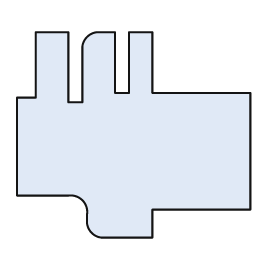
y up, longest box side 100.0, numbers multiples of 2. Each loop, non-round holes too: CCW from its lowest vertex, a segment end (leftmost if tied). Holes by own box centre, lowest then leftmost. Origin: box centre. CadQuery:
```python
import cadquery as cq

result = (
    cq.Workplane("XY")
    .moveTo(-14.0, -44.0)
    .lineTo(8.0, -44.0)
    .lineTo(8.0, -32.0)
    .lineTo(50.0, -32.0)
    .lineTo(50.0, 18.0)
    .lineTo(8.0, 18.0)
    .lineTo(8.0, 44.0)
    .lineTo(-2.0, 44.0)
    .lineTo(-2.0, 18.0)
    .lineTo(-8.0, 18.0)
    .lineTo(-8.0, 44.0)
    .lineTo(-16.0, 44.0)
    .threePointArc((-20.0, 42.0), (-22.0, 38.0))
    .lineTo(-22.0, 14.0)
    .lineTo(-28.0, 14.0)
    .lineTo(-28.0, 44.0)
    .lineTo(-42.0, 44.0)
    .lineTo(-42.0, 16.0)
    .lineTo(-50.0, 16.0)
    .lineTo(-50.0, -26.0)
    .lineTo(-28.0, -26.0)
    .threePointArc((-22.0, -28.0), (-20.0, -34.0))
    .lineTo(-20.0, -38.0)
    .threePointArc((-18.0, -42.0), (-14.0, -44.0))
    .close()
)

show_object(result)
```